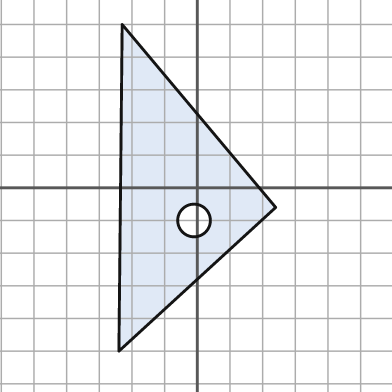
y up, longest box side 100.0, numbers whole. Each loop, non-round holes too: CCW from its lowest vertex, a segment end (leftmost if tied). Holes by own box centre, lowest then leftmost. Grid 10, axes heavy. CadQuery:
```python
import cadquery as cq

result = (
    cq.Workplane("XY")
    .moveTo(-24.0, -50.0)
    .lineTo(24.0, -6.0)
    .lineTo(-23.0, 50.0)
    .close()
    .moveTo(-1.0, -10.0)
    .circle(5.0)
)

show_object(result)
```